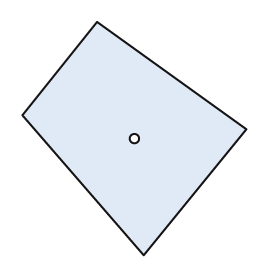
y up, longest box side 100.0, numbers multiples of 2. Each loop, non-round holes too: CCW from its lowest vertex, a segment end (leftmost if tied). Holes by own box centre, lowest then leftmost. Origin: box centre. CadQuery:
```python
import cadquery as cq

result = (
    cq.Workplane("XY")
    .moveTo(4.0, -50.0)
    .lineTo(48.0, 4.0)
    .lineTo(-16.0, 50.0)
    .lineTo(-48.0, 10.0)
    .close()
    .moveTo(0.0, 0.0)
    .circle(2.0)
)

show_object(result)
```